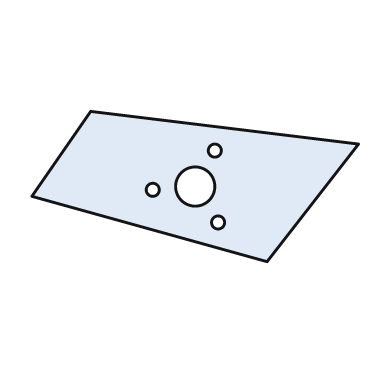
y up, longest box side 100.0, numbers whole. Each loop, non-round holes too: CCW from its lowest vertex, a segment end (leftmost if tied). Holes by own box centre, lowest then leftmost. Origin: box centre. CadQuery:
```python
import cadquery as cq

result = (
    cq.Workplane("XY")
    .moveTo(22.0, -23.0)
    .lineTo(50.0, 13.0)
    .lineTo(-32.0, 23.0)
    .lineTo(-50.0, -3.0)
    .close()
    .moveTo(7.0, -11.0)
    .circle(2.0)
    .moveTo(-13.0, -1.0)
    .circle(2.0)
    .moveTo(0.0, 0.0)
    .circle(6.0)
    .moveTo(6.0, 11.0)
    .circle(2.0)
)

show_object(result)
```